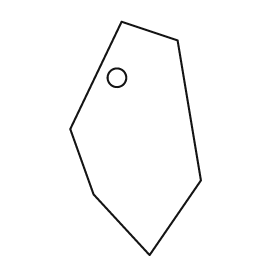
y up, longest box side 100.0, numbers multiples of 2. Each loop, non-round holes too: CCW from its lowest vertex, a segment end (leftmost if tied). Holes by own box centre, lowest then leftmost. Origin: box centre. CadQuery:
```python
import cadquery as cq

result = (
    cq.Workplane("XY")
    .moveTo(6.0, -50.0)
    .lineTo(28.0, -18.0)
    .lineTo(18.0, 42.0)
    .lineTo(-6.0, 50.0)
    .lineTo(-28.0, 4.0)
    .lineTo(-18.0, -24.0)
    .close()
    .moveTo(-8.0, 26.0)
    .circle(4.0)
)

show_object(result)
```